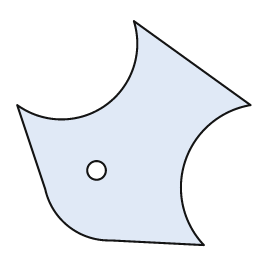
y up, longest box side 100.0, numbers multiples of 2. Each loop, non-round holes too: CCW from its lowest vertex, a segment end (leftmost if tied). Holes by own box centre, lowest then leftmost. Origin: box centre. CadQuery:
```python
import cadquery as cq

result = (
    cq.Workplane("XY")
    .moveTo(30.0, -48.0)
    .threePointArc((22.0, -12.0), (50.0, 12.0))
    .lineTo(0.0, 48.0)
    .threePointArc((-12.0, 12.0), (-50.0, 12.0))
    .lineTo(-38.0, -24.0)
    .threePointArc((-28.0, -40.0), (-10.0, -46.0))
    .close()
    .moveTo(-16.0, -16.0)
    .circle(4.0)
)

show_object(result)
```